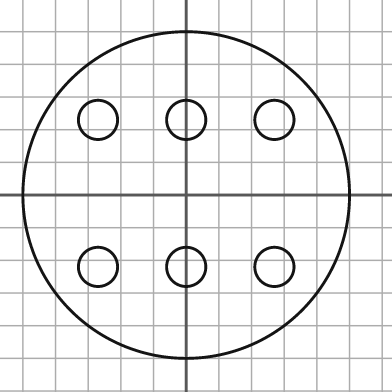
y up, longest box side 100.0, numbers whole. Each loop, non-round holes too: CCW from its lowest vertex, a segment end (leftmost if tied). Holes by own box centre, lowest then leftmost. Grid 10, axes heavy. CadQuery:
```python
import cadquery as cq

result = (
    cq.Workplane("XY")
    .moveTo(0.0, 0.0)
    .circle(50.0)
    .moveTo(-27.0, -22.0)
    .circle(6.0)
    .moveTo(0.0, -22.0)
    .circle(6.0)
    .moveTo(27.0, -22.0)
    .circle(6.0)
    .moveTo(-27.0, 23.0)
    .circle(6.0)
    .moveTo(0.0, 23.0)
    .circle(6.0)
    .moveTo(27.0, 23.0)
    .circle(6.0)
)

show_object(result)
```